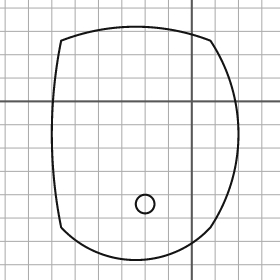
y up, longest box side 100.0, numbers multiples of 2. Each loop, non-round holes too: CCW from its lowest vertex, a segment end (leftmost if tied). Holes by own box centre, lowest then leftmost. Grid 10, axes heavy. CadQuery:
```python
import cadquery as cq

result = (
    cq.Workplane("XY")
    .moveTo(-56.0, -54.0)
    .threePointArc((-24.0, -68.0), (8.0, -54.0))
    .threePointArc((20.0, -14.0), (8.0, 26.0))
    .threePointArc((-24.0, 32.0), (-56.0, 26.0))
    .threePointArc((-60.0, -14.0), (-56.0, -54.0))
    .close()
    .moveTo(-20.0, -44.0)
    .circle(4.0)
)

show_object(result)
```